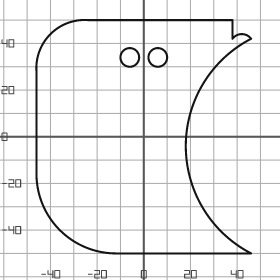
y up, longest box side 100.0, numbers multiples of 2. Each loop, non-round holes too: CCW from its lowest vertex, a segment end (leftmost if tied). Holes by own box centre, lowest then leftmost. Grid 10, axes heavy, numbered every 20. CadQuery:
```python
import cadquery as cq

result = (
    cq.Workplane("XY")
    .moveTo(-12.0, -50.0)
    .lineTo(46.0, -50.0)
    .threePointArc((18.0, -4.0), (46.0, 42.0))
    .threePointArc((42.0, 44.0), (38.0, 42.0))
    .lineTo(38.0, 50.0)
    .lineTo(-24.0, 50.0)
    .threePointArc((-40.0, 44.0), (-46.0, 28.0))
    .lineTo(-46.0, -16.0)
    .threePointArc((-36.0, -40.0), (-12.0, -50.0))
    .close()
    .moveTo(-6.0, 34.0)
    .circle(4.0)
    .moveTo(6.0, 34.0)
    .circle(4.0)
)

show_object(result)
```